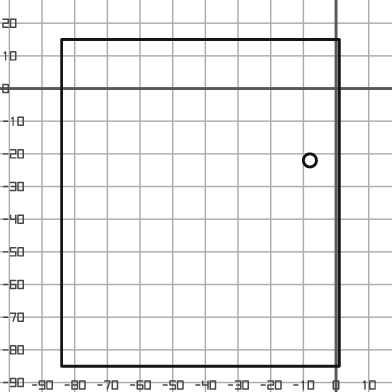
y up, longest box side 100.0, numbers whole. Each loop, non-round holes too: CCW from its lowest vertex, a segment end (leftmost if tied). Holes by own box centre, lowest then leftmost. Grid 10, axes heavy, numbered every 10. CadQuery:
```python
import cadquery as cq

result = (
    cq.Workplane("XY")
    .moveTo(-84.0, -85.0)
    .lineTo(1.0, -85.0)
    .lineTo(1.0, 15.0)
    .lineTo(-84.0, 15.0)
    .close()
    .moveTo(-8.0, -22.0)
    .circle(2.0)
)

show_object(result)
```